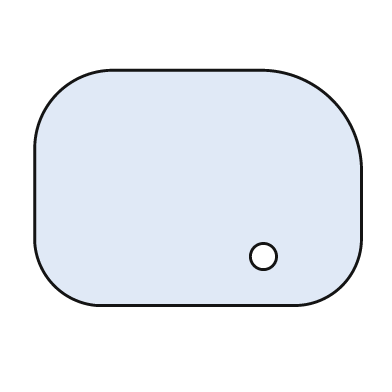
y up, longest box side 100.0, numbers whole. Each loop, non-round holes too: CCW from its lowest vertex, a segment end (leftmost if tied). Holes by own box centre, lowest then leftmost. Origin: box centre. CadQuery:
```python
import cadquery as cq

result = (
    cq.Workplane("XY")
    .moveTo(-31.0, -36.0)
    .lineTo(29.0, -36.0)
    .threePointArc((44.0, -30.0), (50.0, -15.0))
    .lineTo(50.0, 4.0)
    .threePointArc((41.0, 27.0), (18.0, 36.0))
    .lineTo(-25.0, 36.0)
    .threePointArc((-43.0, 29.0), (-50.0, 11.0))
    .lineTo(-50.0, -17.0)
    .threePointArc((-44.0, -30.0), (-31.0, -36.0))
    .close()
    .moveTo(20.0, -21.0)
    .circle(4.0)
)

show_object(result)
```